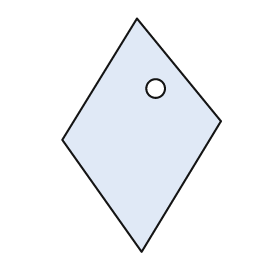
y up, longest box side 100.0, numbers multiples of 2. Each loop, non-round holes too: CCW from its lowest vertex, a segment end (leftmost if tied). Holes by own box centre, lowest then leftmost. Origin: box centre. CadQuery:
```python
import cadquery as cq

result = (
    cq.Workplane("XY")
    .moveTo(0.0, -50.0)
    .lineTo(34.0, 6.0)
    .lineTo(-2.0, 50.0)
    .lineTo(-34.0, -2.0)
    .close()
    .moveTo(6.0, 20.0)
    .circle(4.0)
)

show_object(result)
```